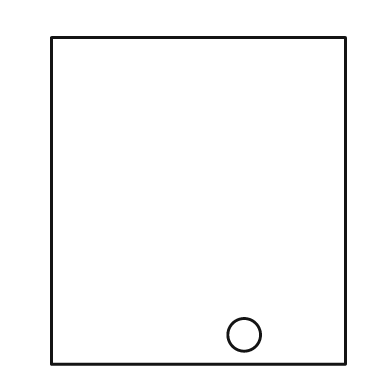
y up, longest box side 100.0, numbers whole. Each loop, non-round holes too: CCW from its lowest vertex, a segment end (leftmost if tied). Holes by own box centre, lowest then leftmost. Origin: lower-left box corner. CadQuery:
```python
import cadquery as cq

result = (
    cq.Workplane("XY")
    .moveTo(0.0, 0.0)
    .lineTo(90.0, 0.0)
    .lineTo(90.0, 100.0)
    .lineTo(0.0, 100.0)
    .close()
    .moveTo(59.0, 9.0)
    .circle(5.0)
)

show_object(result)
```